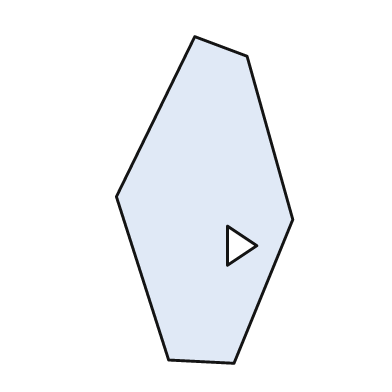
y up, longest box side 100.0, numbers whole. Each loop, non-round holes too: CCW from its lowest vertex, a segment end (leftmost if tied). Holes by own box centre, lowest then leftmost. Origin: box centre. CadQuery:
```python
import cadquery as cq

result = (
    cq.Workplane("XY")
    .moveTo(9.0, -50.0)
    .lineTo(27.0, -6.0)
    .lineTo(13.0, 44.0)
    .lineTo(-3.0, 50.0)
    .lineTo(-27.0, 1.0)
    .lineTo(-11.0, -49.0)
    .close()
    .moveTo(7.0, -20.0)
    .lineTo(16.0, -14.0)
    .lineTo(7.0, -8.0)
    .close()
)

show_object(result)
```